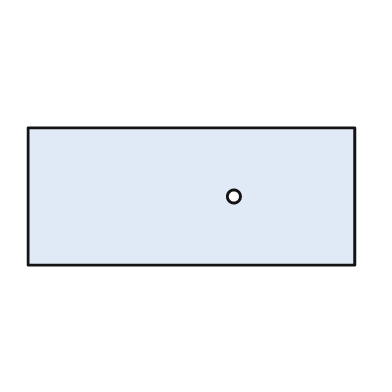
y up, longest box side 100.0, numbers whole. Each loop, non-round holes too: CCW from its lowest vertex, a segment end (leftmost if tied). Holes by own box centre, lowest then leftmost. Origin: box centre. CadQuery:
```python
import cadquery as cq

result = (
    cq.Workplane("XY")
    .moveTo(-50.0, -21.0)
    .lineTo(50.0, -21.0)
    .lineTo(50.0, 21.0)
    .lineTo(-50.0, 21.0)
    .close()
    .moveTo(13.0, 0.0)
    .circle(2.0)
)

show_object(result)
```